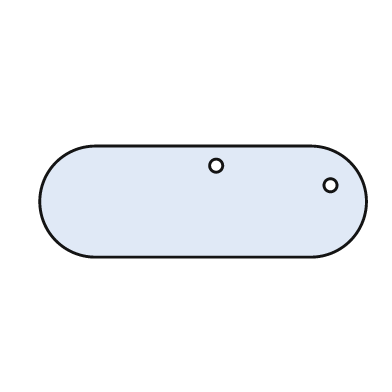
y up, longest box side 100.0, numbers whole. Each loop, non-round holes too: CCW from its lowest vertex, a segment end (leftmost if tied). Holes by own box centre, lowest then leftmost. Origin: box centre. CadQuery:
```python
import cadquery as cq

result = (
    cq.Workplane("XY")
    .moveTo(-33.0, -17.0)
    .lineTo(33.0, -17.0)
    .threePointArc((50.0, 0.0), (33.0, 17.0))
    .lineTo(-33.0, 17.0)
    .threePointArc((-50.0, 0.0), (-33.0, -17.0))
    .close()
    .moveTo(39.0, 5.0)
    .circle(2.0)
    .moveTo(4.0, 11.0)
    .circle(2.0)
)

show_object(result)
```